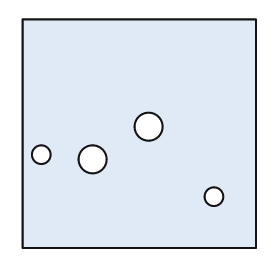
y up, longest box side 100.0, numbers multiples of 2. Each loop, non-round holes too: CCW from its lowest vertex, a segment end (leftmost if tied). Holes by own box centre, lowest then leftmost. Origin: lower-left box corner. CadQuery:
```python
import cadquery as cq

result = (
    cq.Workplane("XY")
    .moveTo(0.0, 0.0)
    .lineTo(100.0, 0.0)
    .lineTo(100.0, 98.0)
    .lineTo(0.0, 98.0)
    .close()
    .moveTo(82.0, 22.0)
    .circle(4.0)
    .moveTo(30.0, 38.0)
    .circle(6.0)
    .moveTo(8.0, 40.0)
    .circle(4.0)
    .moveTo(54.0, 52.0)
    .circle(6.0)
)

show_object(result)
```